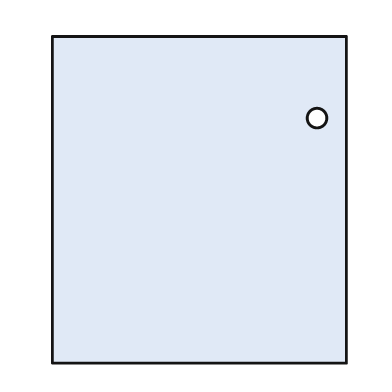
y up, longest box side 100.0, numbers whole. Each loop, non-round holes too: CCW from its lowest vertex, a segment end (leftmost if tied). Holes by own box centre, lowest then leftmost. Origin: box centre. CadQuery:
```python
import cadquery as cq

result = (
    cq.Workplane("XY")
    .moveTo(-45.0, -50.0)
    .lineTo(45.0, -50.0)
    .lineTo(45.0, 50.0)
    .lineTo(-45.0, 50.0)
    .close()
    .moveTo(36.0, 25.0)
    .circle(3.0)
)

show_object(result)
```